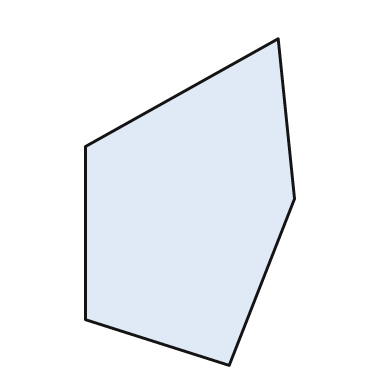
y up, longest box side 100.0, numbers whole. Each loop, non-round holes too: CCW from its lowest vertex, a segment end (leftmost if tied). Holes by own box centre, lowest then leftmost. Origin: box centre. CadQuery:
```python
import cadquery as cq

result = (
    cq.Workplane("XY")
    .moveTo(12.0, -50.0)
    .lineTo(32.0, 1.0)
    .lineTo(27.0, 50.0)
    .lineTo(-32.0, 17.0)
    .lineTo(-32.0, -36.0)
    .close()
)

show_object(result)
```